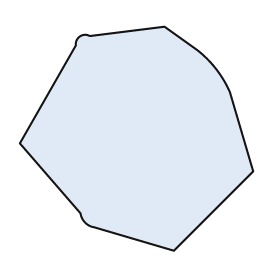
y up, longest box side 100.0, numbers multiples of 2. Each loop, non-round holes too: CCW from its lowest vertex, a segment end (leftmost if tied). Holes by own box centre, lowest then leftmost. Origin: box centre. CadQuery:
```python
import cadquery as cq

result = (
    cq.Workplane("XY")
    .moveTo(16.0, -48.0)
    .lineTo(50.0, -14.0)
    .lineTo(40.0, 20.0)
    .threePointArc((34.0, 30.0), (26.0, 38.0))
    .lineTo(12.0, 48.0)
    .lineTo(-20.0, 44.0)
    .threePointArc((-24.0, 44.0), (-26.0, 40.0))
    .lineTo(-50.0, -2.0)
    .lineTo(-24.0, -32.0)
    .threePointArc((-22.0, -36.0), (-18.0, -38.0))
    .close()
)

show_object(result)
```